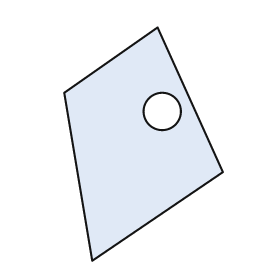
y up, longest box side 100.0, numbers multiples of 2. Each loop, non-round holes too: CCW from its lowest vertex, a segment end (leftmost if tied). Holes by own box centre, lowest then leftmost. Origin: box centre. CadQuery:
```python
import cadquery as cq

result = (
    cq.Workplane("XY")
    .moveTo(-22.0, -50.0)
    .lineTo(34.0, -12.0)
    .lineTo(6.0, 50.0)
    .lineTo(-34.0, 22.0)
    .close()
    .moveTo(8.0, 14.0)
    .circle(8.0)
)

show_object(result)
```